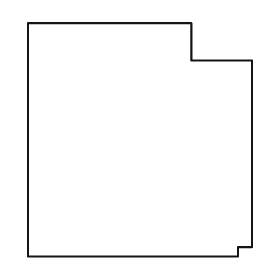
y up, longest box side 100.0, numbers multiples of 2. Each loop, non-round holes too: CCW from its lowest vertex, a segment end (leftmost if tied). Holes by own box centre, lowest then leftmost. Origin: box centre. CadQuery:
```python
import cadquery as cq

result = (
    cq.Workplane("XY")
    .moveTo(-48.0, -50.0)
    .lineTo(42.0, -50.0)
    .lineTo(42.0, -46.0)
    .lineTo(48.0, -46.0)
    .lineTo(48.0, 34.0)
    .lineTo(22.0, 34.0)
    .lineTo(22.0, 50.0)
    .lineTo(-48.0, 50.0)
    .close()
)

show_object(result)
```